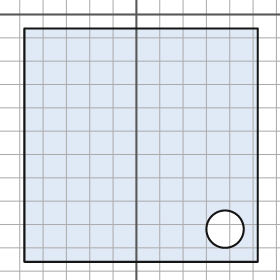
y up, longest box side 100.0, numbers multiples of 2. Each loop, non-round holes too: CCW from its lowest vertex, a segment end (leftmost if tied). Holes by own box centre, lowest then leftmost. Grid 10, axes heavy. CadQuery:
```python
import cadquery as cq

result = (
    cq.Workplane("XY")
    .moveTo(-48.0, -106.0)
    .lineTo(52.0, -106.0)
    .lineTo(52.0, -6.0)
    .lineTo(-48.0, -6.0)
    .close()
    .moveTo(38.0, -92.0)
    .circle(8.0)
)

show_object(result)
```